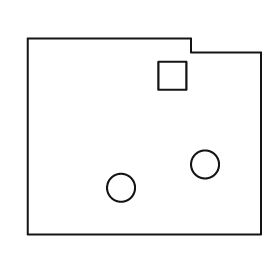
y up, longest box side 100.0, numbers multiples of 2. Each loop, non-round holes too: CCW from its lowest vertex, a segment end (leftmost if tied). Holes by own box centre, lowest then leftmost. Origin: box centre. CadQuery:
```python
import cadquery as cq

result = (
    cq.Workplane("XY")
    .moveTo(-50.0, -42.0)
    .lineTo(50.0, -42.0)
    .lineTo(50.0, 36.0)
    .lineTo(20.0, 36.0)
    .lineTo(20.0, 42.0)
    .lineTo(-50.0, 42.0)
    .close()
    .moveTo(-10.0, -22.0)
    .circle(6.0)
    .moveTo(26.0, -12.0)
    .circle(6.0)
    .moveTo(6.0, 20.0)
    .lineTo(18.0, 20.0)
    .lineTo(18.0, 32.0)
    .lineTo(6.0, 32.0)
    .close()
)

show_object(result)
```